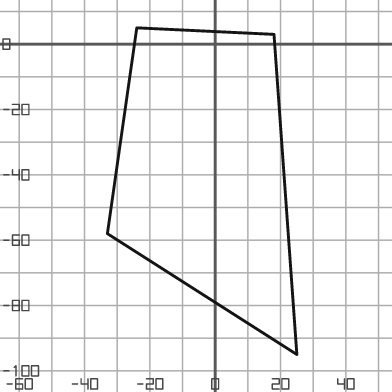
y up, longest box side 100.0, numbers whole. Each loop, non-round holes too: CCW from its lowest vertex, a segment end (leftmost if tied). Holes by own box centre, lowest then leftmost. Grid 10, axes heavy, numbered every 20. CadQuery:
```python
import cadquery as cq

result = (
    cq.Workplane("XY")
    .moveTo(25.0, -95.0)
    .lineTo(18.0, 3.0)
    .lineTo(-24.0, 5.0)
    .lineTo(-33.0, -58.0)
    .close()
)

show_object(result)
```